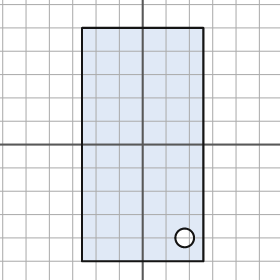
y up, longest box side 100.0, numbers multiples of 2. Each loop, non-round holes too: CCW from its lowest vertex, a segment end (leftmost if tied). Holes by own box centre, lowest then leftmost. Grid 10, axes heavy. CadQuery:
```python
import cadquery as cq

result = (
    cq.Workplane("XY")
    .moveTo(-26.0, -50.0)
    .lineTo(26.0, -50.0)
    .lineTo(26.0, 50.0)
    .lineTo(-26.0, 50.0)
    .close()
    .moveTo(18.0, -40.0)
    .circle(4.0)
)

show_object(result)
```